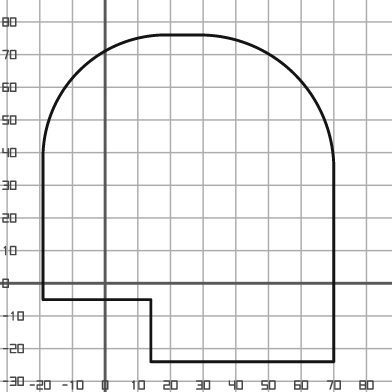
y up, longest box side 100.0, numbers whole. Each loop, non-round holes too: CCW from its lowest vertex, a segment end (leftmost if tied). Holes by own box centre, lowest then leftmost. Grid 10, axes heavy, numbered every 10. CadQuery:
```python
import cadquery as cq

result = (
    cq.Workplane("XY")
    .moveTo(14.0, -24.0)
    .lineTo(70.0, -24.0)
    .lineTo(70.0, 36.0)
    .threePointArc((58.0, 64.0), (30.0, 76.0))
    .lineTo(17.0, 76.0)
    .threePointArc((-8.0, 65.0), (-19.0, 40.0))
    .lineTo(-19.0, -5.0)
    .lineTo(14.0, -5.0)
    .close()
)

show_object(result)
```